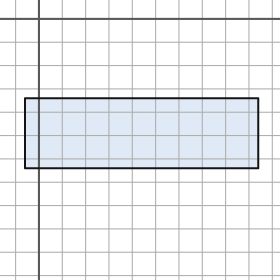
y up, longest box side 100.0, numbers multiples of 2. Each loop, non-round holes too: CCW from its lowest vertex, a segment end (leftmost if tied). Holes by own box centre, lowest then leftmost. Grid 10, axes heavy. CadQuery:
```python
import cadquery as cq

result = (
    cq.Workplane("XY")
    .moveTo(-6.0, -64.0)
    .lineTo(94.0, -64.0)
    .lineTo(94.0, -34.0)
    .lineTo(-6.0, -34.0)
    .close()
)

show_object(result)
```